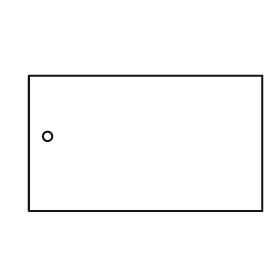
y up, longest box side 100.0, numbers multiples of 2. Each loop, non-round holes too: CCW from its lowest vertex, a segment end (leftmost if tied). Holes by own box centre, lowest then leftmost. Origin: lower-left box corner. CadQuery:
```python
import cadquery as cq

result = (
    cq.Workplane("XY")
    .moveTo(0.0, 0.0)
    .lineTo(100.0, 0.0)
    .lineTo(100.0, 58.0)
    .lineTo(0.0, 58.0)
    .close()
    .moveTo(8.0, 32.0)
    .circle(2.0)
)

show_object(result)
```